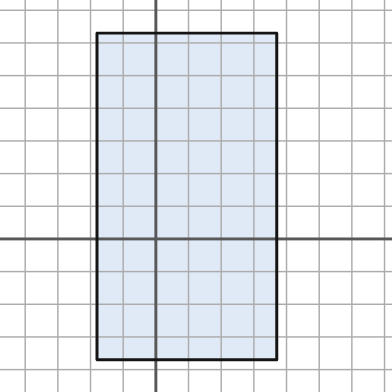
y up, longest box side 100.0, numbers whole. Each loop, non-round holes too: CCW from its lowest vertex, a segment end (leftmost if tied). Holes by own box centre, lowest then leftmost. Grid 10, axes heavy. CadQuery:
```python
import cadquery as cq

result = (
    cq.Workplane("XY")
    .moveTo(-18.0, -37.0)
    .lineTo(37.0, -37.0)
    .lineTo(37.0, 63.0)
    .lineTo(-18.0, 63.0)
    .close()
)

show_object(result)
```